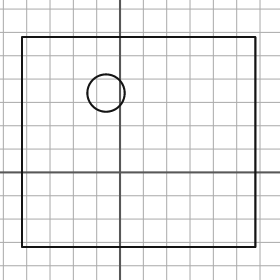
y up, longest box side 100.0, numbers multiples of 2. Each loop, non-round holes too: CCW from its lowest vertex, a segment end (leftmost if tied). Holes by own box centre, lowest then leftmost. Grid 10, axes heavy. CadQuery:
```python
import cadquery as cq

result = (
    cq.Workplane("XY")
    .moveTo(-42.0, -32.0)
    .lineTo(58.0, -32.0)
    .lineTo(58.0, 58.0)
    .lineTo(-42.0, 58.0)
    .close()
    .moveTo(-6.0, 34.0)
    .circle(8.0)
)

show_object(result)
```